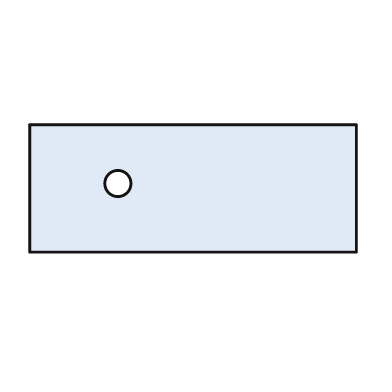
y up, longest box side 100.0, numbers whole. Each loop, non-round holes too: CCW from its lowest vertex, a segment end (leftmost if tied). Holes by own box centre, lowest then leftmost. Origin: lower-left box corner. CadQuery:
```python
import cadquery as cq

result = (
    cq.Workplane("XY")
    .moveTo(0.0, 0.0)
    .lineTo(100.0, 0.0)
    .lineTo(100.0, 39.0)
    .lineTo(0.0, 39.0)
    .close()
    .moveTo(27.0, 21.0)
    .circle(4.0)
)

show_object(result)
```